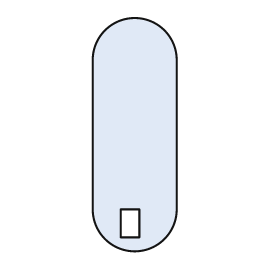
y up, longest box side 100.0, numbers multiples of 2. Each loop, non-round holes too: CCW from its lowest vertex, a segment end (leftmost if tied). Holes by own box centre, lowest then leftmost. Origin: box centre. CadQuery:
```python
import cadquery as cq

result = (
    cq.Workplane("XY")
    .moveTo(-18.0, -32.0)
    .threePointArc((0.0, -50.0), (18.0, -32.0))
    .lineTo(18.0, 32.0)
    .threePointArc((0.0, 50.0), (-18.0, 32.0))
    .close()
    .moveTo(-6.0, -44.0)
    .lineTo(2.0, -44.0)
    .lineTo(2.0, -32.0)
    .lineTo(-6.0, -32.0)
    .close()
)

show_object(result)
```